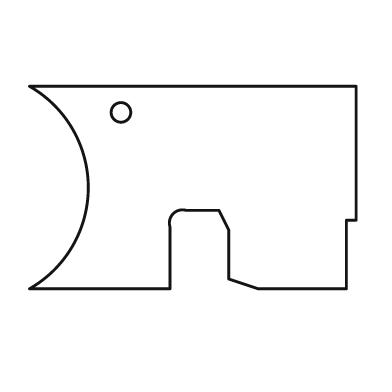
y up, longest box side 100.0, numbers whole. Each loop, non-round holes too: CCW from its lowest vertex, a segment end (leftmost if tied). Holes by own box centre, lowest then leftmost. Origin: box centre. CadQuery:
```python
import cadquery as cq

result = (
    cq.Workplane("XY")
    .moveTo(-50.0, -31.0)
    .lineTo(-7.0, -31.0)
    .lineTo(-7.0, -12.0)
    .threePointArc((-6.0, -8.0), (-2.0, -7.0))
    .lineTo(8.0, -7.0)
    .lineTo(11.0, -13.0)
    .lineTo(11.0, -28.0)
    .lineTo(20.0, -31.0)
    .lineTo(47.0, -31.0)
    .lineTo(47.0, -10.0)
    .lineTo(50.0, -10.0)
    .lineTo(50.0, 31.0)
    .lineTo(-50.0, 31.0)
    .threePointArc((-32.0, 0.0), (-50.0, -31.0))
    .close()
    .moveTo(-22.0, 23.0)
    .circle(3.0)
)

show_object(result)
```